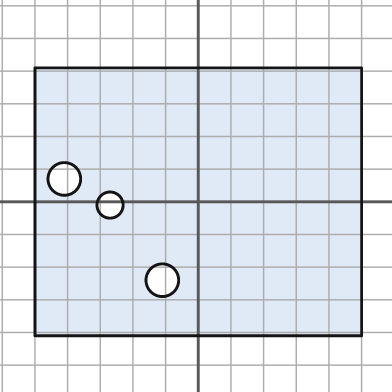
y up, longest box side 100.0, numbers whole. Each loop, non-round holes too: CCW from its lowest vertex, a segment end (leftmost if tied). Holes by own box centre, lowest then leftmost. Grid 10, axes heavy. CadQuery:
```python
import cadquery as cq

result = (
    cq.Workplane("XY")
    .moveTo(-50.0, -41.0)
    .lineTo(50.0, -41.0)
    .lineTo(50.0, 41.0)
    .lineTo(-50.0, 41.0)
    .close()
    .moveTo(-11.0, -24.0)
    .circle(5.0)
    .moveTo(-27.0, -1.0)
    .circle(4.0)
    .moveTo(-41.0, 7.0)
    .circle(5.0)
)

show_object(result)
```